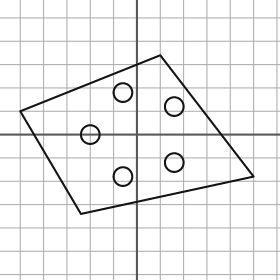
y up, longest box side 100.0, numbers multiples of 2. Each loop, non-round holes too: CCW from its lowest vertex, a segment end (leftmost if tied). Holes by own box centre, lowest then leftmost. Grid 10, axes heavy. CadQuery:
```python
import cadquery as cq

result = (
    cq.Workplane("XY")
    .moveTo(-24.0, -34.0)
    .lineTo(50.0, -18.0)
    .lineTo(10.0, 34.0)
    .lineTo(-50.0, 10.0)
    .close()
    .moveTo(-6.0, -18.0)
    .circle(4.0)
    .moveTo(16.0, -12.0)
    .circle(4.0)
    .moveTo(-20.0, 0.0)
    .circle(4.0)
    .moveTo(16.0, 12.0)
    .circle(4.0)
    .moveTo(-6.0, 18.0)
    .circle(4.0)
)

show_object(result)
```